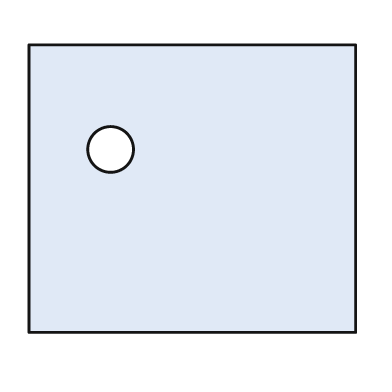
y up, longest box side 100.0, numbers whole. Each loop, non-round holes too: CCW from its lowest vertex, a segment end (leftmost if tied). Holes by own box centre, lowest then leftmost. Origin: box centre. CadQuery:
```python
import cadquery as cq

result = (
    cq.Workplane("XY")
    .moveTo(-50.0, -44.0)
    .lineTo(50.0, -44.0)
    .lineTo(50.0, 44.0)
    .lineTo(-50.0, 44.0)
    .close()
    .moveTo(-25.0, 12.0)
    .circle(7.0)
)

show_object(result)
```